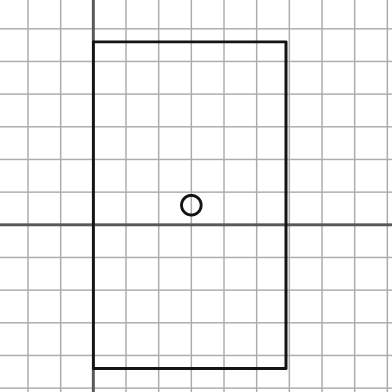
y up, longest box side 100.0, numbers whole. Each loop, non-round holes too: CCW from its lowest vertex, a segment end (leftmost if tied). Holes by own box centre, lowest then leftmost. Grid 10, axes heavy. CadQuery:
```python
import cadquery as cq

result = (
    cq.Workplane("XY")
    .moveTo(0.0, -44.0)
    .lineTo(59.0, -44.0)
    .lineTo(59.0, 56.0)
    .lineTo(0.0, 56.0)
    .close()
    .moveTo(30.0, 6.0)
    .circle(3.0)
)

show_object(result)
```